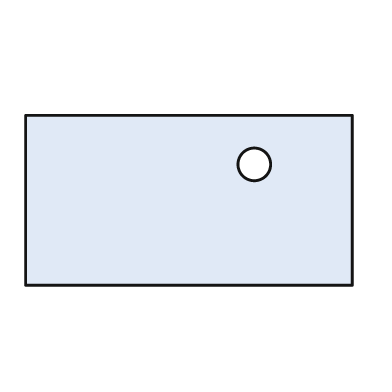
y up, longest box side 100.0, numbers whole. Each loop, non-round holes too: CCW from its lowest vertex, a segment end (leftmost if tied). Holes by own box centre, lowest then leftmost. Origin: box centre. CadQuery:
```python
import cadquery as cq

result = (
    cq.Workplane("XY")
    .moveTo(-50.0, -26.0)
    .lineTo(50.0, -26.0)
    .lineTo(50.0, 26.0)
    .lineTo(-50.0, 26.0)
    .close()
    .moveTo(20.0, 11.0)
    .circle(5.0)
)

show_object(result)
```